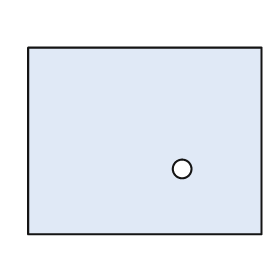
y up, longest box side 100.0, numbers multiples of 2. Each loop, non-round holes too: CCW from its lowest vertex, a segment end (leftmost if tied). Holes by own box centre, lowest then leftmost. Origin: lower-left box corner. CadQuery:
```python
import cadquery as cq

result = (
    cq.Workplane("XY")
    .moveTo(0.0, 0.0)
    .lineTo(100.0, 0.0)
    .lineTo(100.0, 80.0)
    .lineTo(0.0, 80.0)
    .close()
    .moveTo(66.0, 28.0)
    .circle(4.0)
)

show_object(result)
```